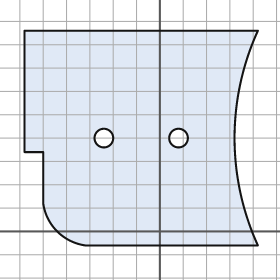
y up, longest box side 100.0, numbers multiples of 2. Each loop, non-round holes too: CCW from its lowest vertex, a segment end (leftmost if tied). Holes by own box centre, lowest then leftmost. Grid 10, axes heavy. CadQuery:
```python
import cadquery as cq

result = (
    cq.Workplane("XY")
    .moveTo(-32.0, -6.0)
    .lineTo(42.0, -6.0)
    .threePointArc((32.0, 40.0), (42.0, 86.0))
    .lineTo(-58.0, 86.0)
    .lineTo(-58.0, 34.0)
    .lineTo(-50.0, 34.0)
    .lineTo(-50.0, 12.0)
    .threePointArc((-44.0, 0.0), (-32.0, -6.0))
    .close()
    .moveTo(-24.0, 40.0)
    .circle(4.0)
    .moveTo(8.0, 40.0)
    .circle(4.0)
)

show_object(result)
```